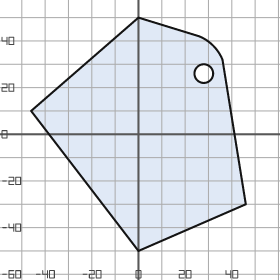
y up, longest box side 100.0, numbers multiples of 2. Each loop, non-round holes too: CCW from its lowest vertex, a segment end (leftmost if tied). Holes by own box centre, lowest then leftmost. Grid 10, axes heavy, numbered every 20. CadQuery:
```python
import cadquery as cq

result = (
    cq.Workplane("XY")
    .moveTo(0.0, -50.0)
    .lineTo(46.0, -30.0)
    .lineTo(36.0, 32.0)
    .threePointArc((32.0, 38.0), (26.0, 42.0))
    .lineTo(0.0, 50.0)
    .lineTo(-46.0, 10.0)
    .close()
    .moveTo(28.0, 26.0)
    .circle(4.0)
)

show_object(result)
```